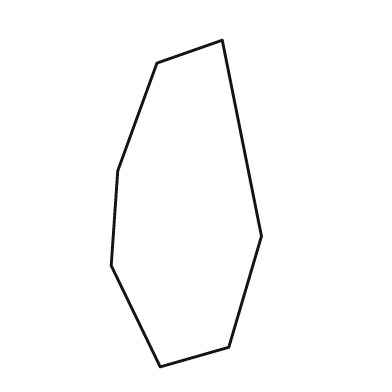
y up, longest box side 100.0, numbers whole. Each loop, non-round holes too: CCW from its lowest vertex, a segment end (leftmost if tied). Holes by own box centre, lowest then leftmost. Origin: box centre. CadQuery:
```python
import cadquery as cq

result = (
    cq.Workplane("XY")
    .moveTo(-8.0, -50.0)
    .lineTo(13.0, -44.0)
    .lineTo(23.0, -10.0)
    .lineTo(11.0, 50.0)
    .lineTo(-9.0, 43.0)
    .lineTo(-21.0, 10.0)
    .lineTo(-23.0, -19.0)
    .close()
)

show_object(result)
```